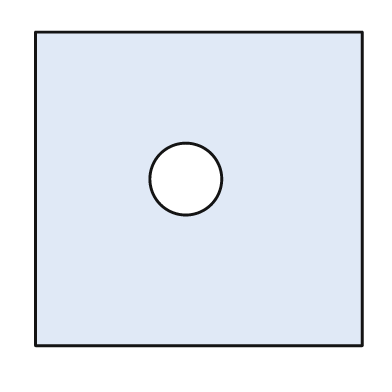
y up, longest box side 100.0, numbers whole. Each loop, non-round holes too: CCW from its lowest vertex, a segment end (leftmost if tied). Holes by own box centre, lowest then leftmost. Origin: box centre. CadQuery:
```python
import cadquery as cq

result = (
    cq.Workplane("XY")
    .moveTo(-50.0, -48.0)
    .lineTo(50.0, -48.0)
    .lineTo(50.0, 48.0)
    .lineTo(-50.0, 48.0)
    .close()
    .moveTo(-4.0, 3.0)
    .circle(11.0)
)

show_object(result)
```